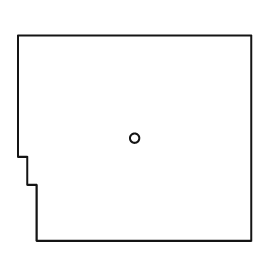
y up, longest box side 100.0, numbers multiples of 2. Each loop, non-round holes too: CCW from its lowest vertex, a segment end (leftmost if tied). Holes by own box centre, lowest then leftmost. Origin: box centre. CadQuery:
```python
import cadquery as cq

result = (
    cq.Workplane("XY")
    .moveTo(-42.0, -44.0)
    .lineTo(50.0, -44.0)
    .lineTo(50.0, 44.0)
    .lineTo(-50.0, 44.0)
    .lineTo(-50.0, -8.0)
    .lineTo(-46.0, -8.0)
    .lineTo(-46.0, -20.0)
    .lineTo(-42.0, -20.0)
    .close()
    .moveTo(0.0, 0.0)
    .circle(2.0)
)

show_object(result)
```